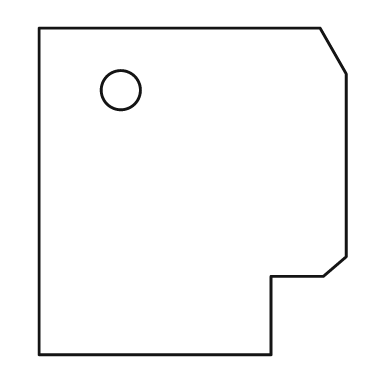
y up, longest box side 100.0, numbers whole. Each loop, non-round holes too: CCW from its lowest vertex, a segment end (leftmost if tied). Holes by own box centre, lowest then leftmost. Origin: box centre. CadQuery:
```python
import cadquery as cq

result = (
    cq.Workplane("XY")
    .moveTo(-47.0, -50.0)
    .lineTo(24.0, -50.0)
    .lineTo(24.0, -26.0)
    .lineTo(40.0, -26.0)
    .lineTo(47.0, -20.0)
    .lineTo(47.0, 36.0)
    .lineTo(39.0, 50.0)
    .lineTo(-47.0, 50.0)
    .close()
    .moveTo(-22.0, 31.0)
    .circle(6.0)
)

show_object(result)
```